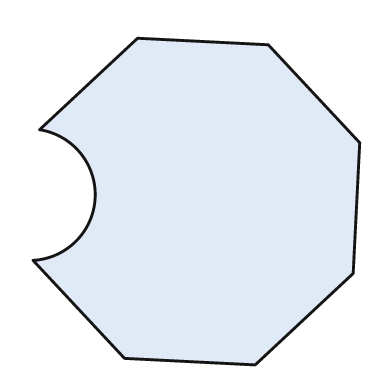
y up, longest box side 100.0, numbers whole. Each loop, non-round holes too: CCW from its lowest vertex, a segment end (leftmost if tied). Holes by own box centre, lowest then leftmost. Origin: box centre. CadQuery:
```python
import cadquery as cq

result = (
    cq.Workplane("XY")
    .moveTo(18.0, -50.0)
    .lineTo(48.0, -22.0)
    .lineTo(50.0, 18.0)
    .lineTo(22.0, 48.0)
    .lineTo(-18.0, 50.0)
    .lineTo(-48.0, 22.0)
    .threePointArc((-31.0, 1.0), (-50.0, -18.0))
    .lineTo(-22.0, -48.0)
    .close()
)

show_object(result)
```